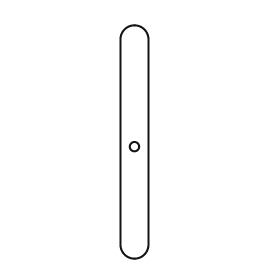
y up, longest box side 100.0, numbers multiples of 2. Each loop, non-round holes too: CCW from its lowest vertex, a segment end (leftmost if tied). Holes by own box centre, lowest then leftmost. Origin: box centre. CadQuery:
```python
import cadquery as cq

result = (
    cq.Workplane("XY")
    .moveTo(-6.0, -44.0)
    .threePointArc((0.0, -50.0), (6.0, -44.0))
    .lineTo(6.0, 44.0)
    .threePointArc((0.0, 50.0), (-6.0, 44.0))
    .close()
    .moveTo(0.0, -2.0)
    .circle(2.0)
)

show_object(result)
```